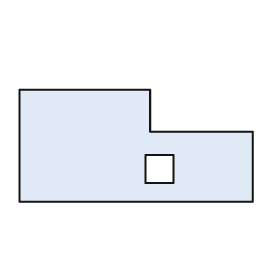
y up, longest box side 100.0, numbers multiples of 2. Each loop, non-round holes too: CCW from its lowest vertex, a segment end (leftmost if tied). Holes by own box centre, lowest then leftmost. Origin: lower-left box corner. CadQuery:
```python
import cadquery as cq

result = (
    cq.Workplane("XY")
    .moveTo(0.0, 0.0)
    .lineTo(100.0, 0.0)
    .lineTo(100.0, 30.0)
    .lineTo(56.0, 30.0)
    .lineTo(56.0, 48.0)
    .lineTo(0.0, 48.0)
    .close()
    .moveTo(54.0, 8.0)
    .lineTo(66.0, 8.0)
    .lineTo(66.0, 20.0)
    .lineTo(54.0, 20.0)
    .close()
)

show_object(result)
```